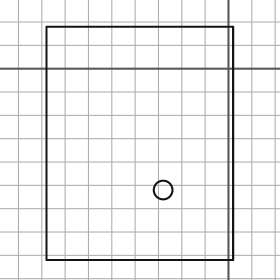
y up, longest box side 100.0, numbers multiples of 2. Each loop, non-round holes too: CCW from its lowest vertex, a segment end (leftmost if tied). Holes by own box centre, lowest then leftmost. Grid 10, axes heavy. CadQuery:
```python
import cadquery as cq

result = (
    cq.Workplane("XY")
    .moveTo(-78.0, -82.0)
    .lineTo(2.0, -82.0)
    .lineTo(2.0, 18.0)
    .lineTo(-78.0, 18.0)
    .close()
    .moveTo(-28.0, -52.0)
    .circle(4.0)
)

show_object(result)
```